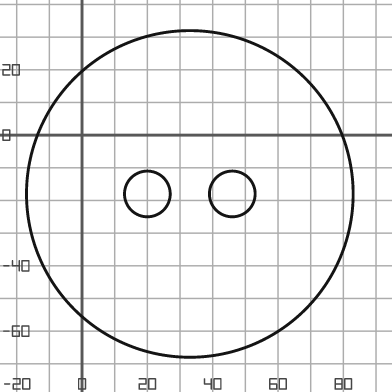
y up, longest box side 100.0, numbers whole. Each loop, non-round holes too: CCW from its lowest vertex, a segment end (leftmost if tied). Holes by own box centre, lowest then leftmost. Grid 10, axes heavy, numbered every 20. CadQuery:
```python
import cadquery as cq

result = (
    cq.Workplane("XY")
    .moveTo(33.0, -18.0)
    .circle(50.0)
    .moveTo(20.0, -18.0)
    .circle(7.0)
    .moveTo(46.0, -18.0)
    .circle(7.0)
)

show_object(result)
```